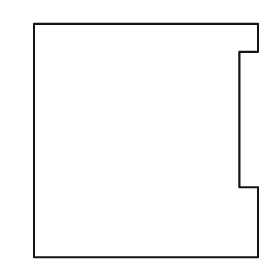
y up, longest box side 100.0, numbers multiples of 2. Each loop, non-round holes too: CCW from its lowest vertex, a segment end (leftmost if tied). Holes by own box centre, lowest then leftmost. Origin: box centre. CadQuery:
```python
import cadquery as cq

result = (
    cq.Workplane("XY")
    .moveTo(-48.0, -50.0)
    .lineTo(48.0, -50.0)
    .lineTo(48.0, -20.0)
    .lineTo(40.0, -20.0)
    .lineTo(40.0, 38.0)
    .lineTo(48.0, 38.0)
    .lineTo(48.0, 50.0)
    .lineTo(-48.0, 50.0)
    .close()
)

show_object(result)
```